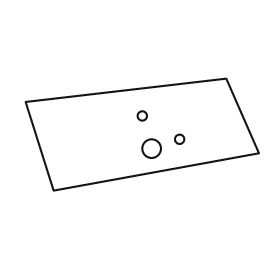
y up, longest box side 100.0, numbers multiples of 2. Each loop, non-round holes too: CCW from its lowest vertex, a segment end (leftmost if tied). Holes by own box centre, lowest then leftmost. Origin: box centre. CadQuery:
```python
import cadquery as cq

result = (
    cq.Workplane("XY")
    .moveTo(-38.0, -24.0)
    .lineTo(50.0, -8.0)
    .lineTo(36.0, 24.0)
    .lineTo(-50.0, 14.0)
    .close()
    .moveTo(4.0, -6.0)
    .circle(4.0)
    .moveTo(16.0, -2.0)
    .circle(2.0)
    .moveTo(0.0, 8.0)
    .circle(2.0)
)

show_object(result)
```